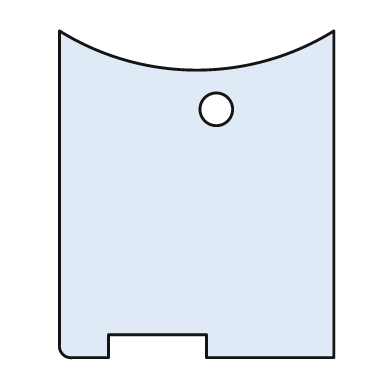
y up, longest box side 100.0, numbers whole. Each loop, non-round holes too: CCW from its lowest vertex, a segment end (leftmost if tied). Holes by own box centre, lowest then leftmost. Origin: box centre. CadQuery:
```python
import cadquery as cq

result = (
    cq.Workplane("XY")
    .moveTo(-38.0, -50.0)
    .lineTo(-27.0, -50.0)
    .lineTo(-27.0, -43.0)
    .lineTo(3.0, -43.0)
    .lineTo(3.0, -50.0)
    .lineTo(42.0, -50.0)
    .lineTo(42.0, 50.0)
    .threePointArc((0.0, 38.0), (-42.0, 50.0))
    .lineTo(-42.0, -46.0)
    .threePointArc((-41.0, -49.0), (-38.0, -50.0))
    .close()
    .moveTo(6.0, 26.0)
    .circle(5.0)
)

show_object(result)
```